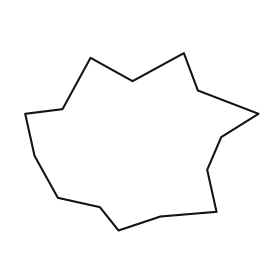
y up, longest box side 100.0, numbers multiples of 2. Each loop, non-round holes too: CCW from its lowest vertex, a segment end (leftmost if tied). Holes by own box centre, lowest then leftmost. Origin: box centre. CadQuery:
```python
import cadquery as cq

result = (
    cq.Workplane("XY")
    .moveTo(-10.0, -38.0)
    .lineTo(8.0, -32.0)
    .lineTo(32.0, -30.0)
    .lineTo(28.0, -12.0)
    .lineTo(34.0, 2.0)
    .lineTo(50.0, 12.0)
    .lineTo(24.0, 22.0)
    .lineTo(18.0, 38.0)
    .lineTo(-4.0, 26.0)
    .lineTo(-22.0, 36.0)
    .lineTo(-34.0, 14.0)
    .lineTo(-50.0, 12.0)
    .lineTo(-46.0, -6.0)
    .lineTo(-36.0, -24.0)
    .lineTo(-18.0, -28.0)
    .close()
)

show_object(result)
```